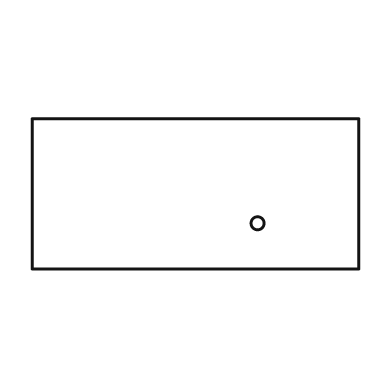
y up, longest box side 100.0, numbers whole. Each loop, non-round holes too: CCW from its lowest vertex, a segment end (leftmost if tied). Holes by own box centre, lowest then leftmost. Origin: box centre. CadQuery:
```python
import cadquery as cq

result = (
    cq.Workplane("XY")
    .moveTo(-50.0, -23.0)
    .lineTo(50.0, -23.0)
    .lineTo(50.0, 23.0)
    .lineTo(-50.0, 23.0)
    .close()
    .moveTo(19.0, -9.0)
    .circle(2.0)
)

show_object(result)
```